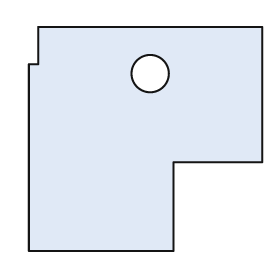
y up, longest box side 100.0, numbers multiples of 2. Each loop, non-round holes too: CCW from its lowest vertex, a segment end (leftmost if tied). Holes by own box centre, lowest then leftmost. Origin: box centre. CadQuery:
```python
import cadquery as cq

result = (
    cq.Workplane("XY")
    .moveTo(-50.0, -48.0)
    .lineTo(12.0, -48.0)
    .lineTo(12.0, -10.0)
    .lineTo(50.0, -10.0)
    .lineTo(50.0, 48.0)
    .lineTo(-46.0, 48.0)
    .lineTo(-46.0, 32.0)
    .lineTo(-50.0, 32.0)
    .close()
    .moveTo(2.0, 28.0)
    .circle(8.0)
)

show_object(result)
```